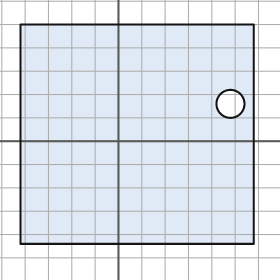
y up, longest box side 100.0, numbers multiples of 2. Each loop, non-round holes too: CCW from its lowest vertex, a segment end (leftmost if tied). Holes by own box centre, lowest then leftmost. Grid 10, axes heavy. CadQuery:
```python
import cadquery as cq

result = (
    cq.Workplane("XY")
    .moveTo(-42.0, -44.0)
    .lineTo(58.0, -44.0)
    .lineTo(58.0, 50.0)
    .lineTo(-42.0, 50.0)
    .close()
    .moveTo(48.0, 16.0)
    .circle(6.0)
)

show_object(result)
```